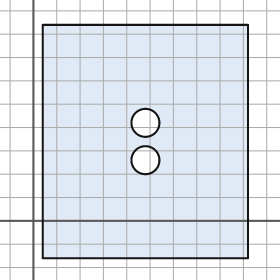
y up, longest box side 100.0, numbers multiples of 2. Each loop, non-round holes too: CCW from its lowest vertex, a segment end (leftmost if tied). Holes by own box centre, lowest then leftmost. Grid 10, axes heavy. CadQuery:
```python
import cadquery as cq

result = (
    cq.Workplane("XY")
    .moveTo(4.0, -16.0)
    .lineTo(92.0, -16.0)
    .lineTo(92.0, 84.0)
    .lineTo(4.0, 84.0)
    .close()
    .moveTo(48.0, 26.0)
    .circle(6.0)
    .moveTo(48.0, 42.0)
    .circle(6.0)
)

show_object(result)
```